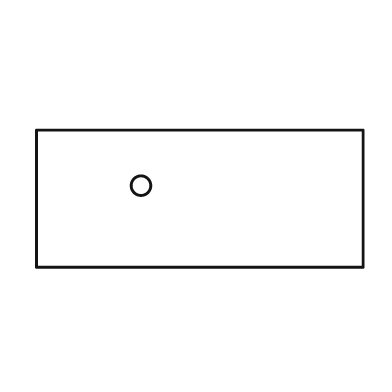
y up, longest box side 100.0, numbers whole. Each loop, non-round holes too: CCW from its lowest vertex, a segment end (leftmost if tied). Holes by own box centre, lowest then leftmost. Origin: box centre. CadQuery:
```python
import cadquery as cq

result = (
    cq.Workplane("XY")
    .moveTo(-50.0, -21.0)
    .lineTo(50.0, -21.0)
    .lineTo(50.0, 21.0)
    .lineTo(-50.0, 21.0)
    .close()
    .moveTo(-18.0, 4.0)
    .circle(3.0)
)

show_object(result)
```